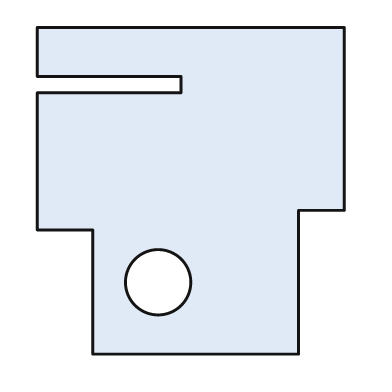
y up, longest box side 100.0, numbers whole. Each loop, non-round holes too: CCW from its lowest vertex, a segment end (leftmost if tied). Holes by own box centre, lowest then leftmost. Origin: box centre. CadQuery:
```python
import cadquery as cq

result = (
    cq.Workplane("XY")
    .moveTo(-30.0, -50.0)
    .lineTo(33.0, -50.0)
    .lineTo(33.0, -6.0)
    .lineTo(47.0, -6.0)
    .lineTo(47.0, 50.0)
    .lineTo(-47.0, 50.0)
    .lineTo(-47.0, 35.0)
    .lineTo(-3.0, 35.0)
    .lineTo(-3.0, 30.0)
    .lineTo(-47.0, 30.0)
    .lineTo(-47.0, -12.0)
    .lineTo(-30.0, -12.0)
    .close()
    .moveTo(-10.0, -28.0)
    .circle(10.0)
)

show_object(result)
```